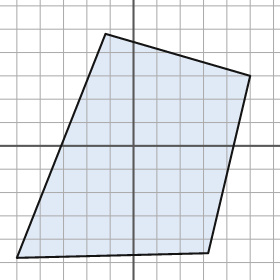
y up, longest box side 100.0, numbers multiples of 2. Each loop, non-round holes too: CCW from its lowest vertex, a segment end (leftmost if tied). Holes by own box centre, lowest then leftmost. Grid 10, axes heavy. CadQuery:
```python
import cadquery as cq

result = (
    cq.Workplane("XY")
    .moveTo(-50.0, -48.0)
    .lineTo(32.0, -46.0)
    .lineTo(50.0, 30.0)
    .lineTo(-12.0, 48.0)
    .close()
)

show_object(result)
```